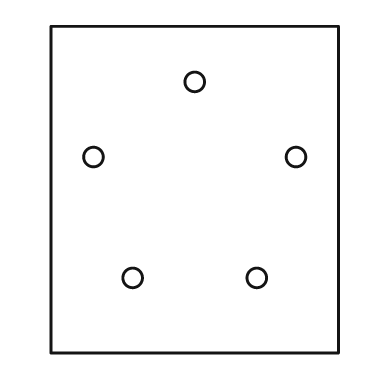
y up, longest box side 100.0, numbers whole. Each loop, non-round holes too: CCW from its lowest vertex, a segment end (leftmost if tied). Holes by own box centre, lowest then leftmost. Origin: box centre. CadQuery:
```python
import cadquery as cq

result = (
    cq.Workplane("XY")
    .moveTo(-44.0, -50.0)
    .lineTo(44.0, -50.0)
    .lineTo(44.0, 50.0)
    .lineTo(-44.0, 50.0)
    .close()
    .moveTo(-19.0, -27.0)
    .circle(3.0)
    .moveTo(19.0, -27.0)
    .circle(3.0)
    .moveTo(-31.0, 10.0)
    .circle(3.0)
    .moveTo(31.0, 10.0)
    .circle(3.0)
    .moveTo(0.0, 33.0)
    .circle(3.0)
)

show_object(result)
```